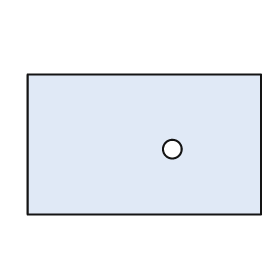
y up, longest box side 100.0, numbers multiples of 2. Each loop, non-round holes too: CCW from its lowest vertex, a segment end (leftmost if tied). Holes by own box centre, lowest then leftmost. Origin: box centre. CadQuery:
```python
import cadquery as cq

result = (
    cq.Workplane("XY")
    .moveTo(-50.0, -30.0)
    .lineTo(50.0, -30.0)
    .lineTo(50.0, 30.0)
    .lineTo(-50.0, 30.0)
    .close()
    .moveTo(12.0, -2.0)
    .circle(4.0)
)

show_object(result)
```